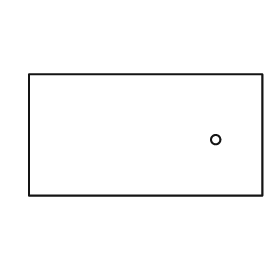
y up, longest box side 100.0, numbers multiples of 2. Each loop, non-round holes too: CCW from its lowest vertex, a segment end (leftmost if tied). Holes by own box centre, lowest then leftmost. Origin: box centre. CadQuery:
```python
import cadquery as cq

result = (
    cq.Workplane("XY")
    .moveTo(-50.0, -26.0)
    .lineTo(50.0, -26.0)
    .lineTo(50.0, 26.0)
    .lineTo(-50.0, 26.0)
    .close()
    .moveTo(30.0, -2.0)
    .circle(2.0)
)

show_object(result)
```